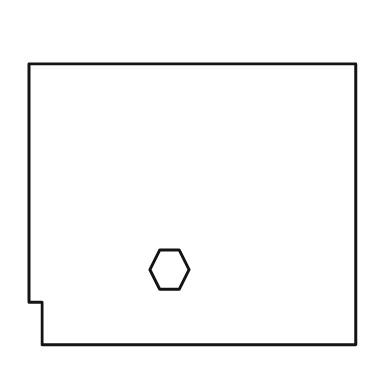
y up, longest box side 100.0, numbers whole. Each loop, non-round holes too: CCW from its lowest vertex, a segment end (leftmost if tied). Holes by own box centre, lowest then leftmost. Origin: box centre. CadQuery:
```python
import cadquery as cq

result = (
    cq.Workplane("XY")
    .moveTo(-46.0, -43.0)
    .lineTo(50.0, -43.0)
    .lineTo(50.0, 43.0)
    .lineTo(-50.0, 43.0)
    .lineTo(-50.0, -30.0)
    .lineTo(-46.0, -30.0)
    .close()
    .moveTo(-10.0, -26.0)
    .lineTo(-4.0, -26.0)
    .lineTo(-1.0, -20.0)
    .lineTo(-4.0, -14.0)
    .lineTo(-10.0, -14.0)
    .lineTo(-13.0, -20.0)
    .close()
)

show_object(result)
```